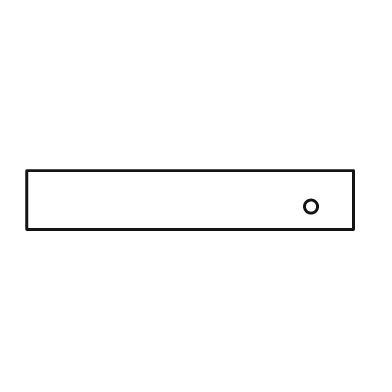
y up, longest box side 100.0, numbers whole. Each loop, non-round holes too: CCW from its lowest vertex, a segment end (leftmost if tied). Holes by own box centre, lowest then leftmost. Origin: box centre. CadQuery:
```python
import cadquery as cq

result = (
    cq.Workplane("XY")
    .moveTo(-50.0, -9.0)
    .lineTo(50.0, -9.0)
    .lineTo(50.0, 9.0)
    .lineTo(-50.0, 9.0)
    .close()
    .moveTo(37.0, -2.0)
    .circle(2.0)
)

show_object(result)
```